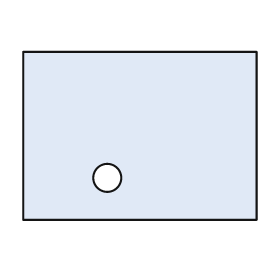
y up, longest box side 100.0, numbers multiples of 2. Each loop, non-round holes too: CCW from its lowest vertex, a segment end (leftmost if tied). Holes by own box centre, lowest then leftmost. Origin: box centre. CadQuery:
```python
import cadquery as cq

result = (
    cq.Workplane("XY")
    .moveTo(-50.0, -36.0)
    .lineTo(50.0, -36.0)
    .lineTo(50.0, 36.0)
    .lineTo(-50.0, 36.0)
    .close()
    .moveTo(-14.0, -18.0)
    .circle(6.0)
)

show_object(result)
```